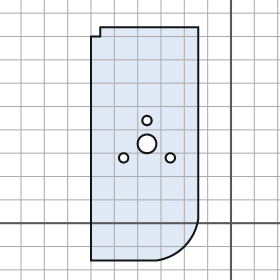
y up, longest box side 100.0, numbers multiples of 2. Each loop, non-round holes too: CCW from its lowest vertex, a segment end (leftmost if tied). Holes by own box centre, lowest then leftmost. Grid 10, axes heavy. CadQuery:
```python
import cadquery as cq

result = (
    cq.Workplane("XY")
    .moveTo(-60.0, -16.0)
    .lineTo(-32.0, -16.0)
    .threePointArc((-20.0, -10.0), (-14.0, 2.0))
    .lineTo(-14.0, 84.0)
    .lineTo(-56.0, 84.0)
    .lineTo(-56.0, 80.0)
    .lineTo(-60.0, 80.0)
    .close()
    .moveTo(-46.0, 28.0)
    .circle(2.0)
    .moveTo(-26.0, 28.0)
    .circle(2.0)
    .moveTo(-36.0, 34.0)
    .circle(4.0)
    .moveTo(-36.0, 44.0)
    .circle(2.0)
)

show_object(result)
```